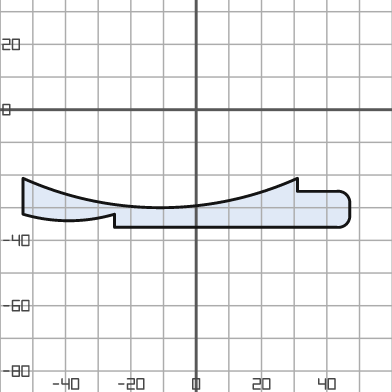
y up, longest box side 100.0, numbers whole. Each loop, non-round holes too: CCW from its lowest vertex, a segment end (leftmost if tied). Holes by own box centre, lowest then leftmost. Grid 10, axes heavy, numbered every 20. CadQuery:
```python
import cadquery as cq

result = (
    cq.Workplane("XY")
    .moveTo(-25.0, -36.0)
    .lineTo(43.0, -36.0)
    .threePointArc((46.0, -35.0), (47.0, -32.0))
    .lineTo(47.0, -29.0)
    .threePointArc((46.0, -26.0), (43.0, -25.0))
    .lineTo(31.0, -25.0)
    .lineTo(31.0, -21.0)
    .threePointArc((-11.0, -30.0), (-53.0, -21.0))
    .lineTo(-53.0, -32.0)
    .threePointArc((-39.0, -34.0), (-25.0, -32.0))
    .close()
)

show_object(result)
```